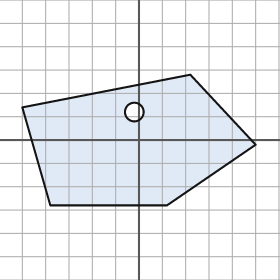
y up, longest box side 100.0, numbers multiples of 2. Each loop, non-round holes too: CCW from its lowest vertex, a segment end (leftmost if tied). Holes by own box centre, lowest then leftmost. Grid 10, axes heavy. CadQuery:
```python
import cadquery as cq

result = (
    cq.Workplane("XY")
    .moveTo(-38.0, -28.0)
    .lineTo(12.0, -28.0)
    .lineTo(50.0, -2.0)
    .lineTo(22.0, 28.0)
    .lineTo(-50.0, 14.0)
    .close()
    .moveTo(-2.0, 12.0)
    .circle(4.0)
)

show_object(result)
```